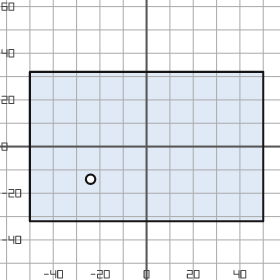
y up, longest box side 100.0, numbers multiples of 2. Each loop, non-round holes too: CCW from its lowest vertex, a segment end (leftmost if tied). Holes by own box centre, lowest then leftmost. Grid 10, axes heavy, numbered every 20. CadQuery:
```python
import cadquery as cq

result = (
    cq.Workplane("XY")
    .moveTo(-50.0, -32.0)
    .lineTo(50.0, -32.0)
    .lineTo(50.0, 32.0)
    .lineTo(-50.0, 32.0)
    .close()
    .moveTo(-24.0, -14.0)
    .circle(2.0)
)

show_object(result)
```